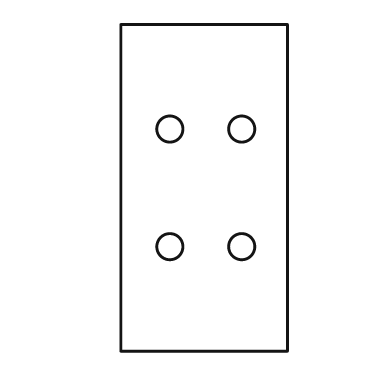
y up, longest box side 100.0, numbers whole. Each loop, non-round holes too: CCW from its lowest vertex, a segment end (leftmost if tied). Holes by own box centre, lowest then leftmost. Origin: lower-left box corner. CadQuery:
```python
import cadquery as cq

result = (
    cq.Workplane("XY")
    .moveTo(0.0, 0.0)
    .lineTo(51.0, 0.0)
    .lineTo(51.0, 100.0)
    .lineTo(0.0, 100.0)
    .close()
    .moveTo(15.0, 32.0)
    .circle(4.0)
    .moveTo(37.0, 32.0)
    .circle(4.0)
    .moveTo(15.0, 68.0)
    .circle(4.0)
    .moveTo(37.0, 68.0)
    .circle(4.0)
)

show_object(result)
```